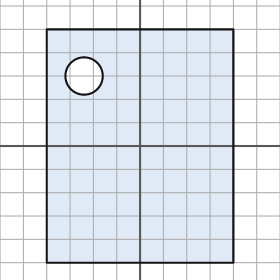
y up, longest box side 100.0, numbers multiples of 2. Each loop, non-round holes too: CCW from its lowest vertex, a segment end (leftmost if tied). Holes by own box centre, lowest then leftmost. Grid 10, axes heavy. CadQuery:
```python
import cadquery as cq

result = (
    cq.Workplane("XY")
    .moveTo(-40.0, -50.0)
    .lineTo(40.0, -50.0)
    .lineTo(40.0, 50.0)
    .lineTo(-40.0, 50.0)
    .close()
    .moveTo(-24.0, 30.0)
    .circle(8.0)
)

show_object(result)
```